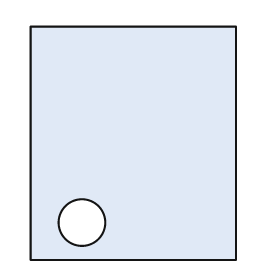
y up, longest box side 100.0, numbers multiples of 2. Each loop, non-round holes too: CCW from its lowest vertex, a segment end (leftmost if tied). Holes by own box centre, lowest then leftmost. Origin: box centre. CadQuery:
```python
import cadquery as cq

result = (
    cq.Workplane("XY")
    .moveTo(-44.0, -50.0)
    .lineTo(44.0, -50.0)
    .lineTo(44.0, 50.0)
    .lineTo(-44.0, 50.0)
    .close()
    .moveTo(-22.0, -34.0)
    .circle(10.0)
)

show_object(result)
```